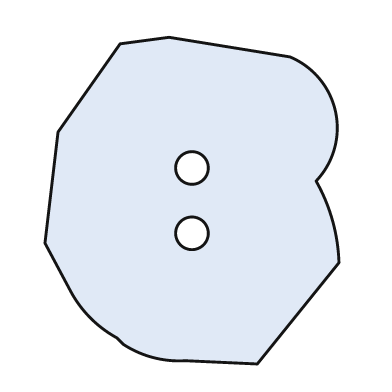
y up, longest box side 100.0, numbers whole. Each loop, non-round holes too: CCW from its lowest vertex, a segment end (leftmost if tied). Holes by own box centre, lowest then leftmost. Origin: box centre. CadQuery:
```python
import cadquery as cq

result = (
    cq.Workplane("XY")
    .moveTo(20.0, -50.0)
    .lineTo(45.0, -19.0)
    .threePointArc((43.0, -6.0), (38.0, 6.0))
    .threePointArc((44.0, 27.0), (30.0, 44.0))
    .lineTo(-7.0, 50.0)
    .lineTo(-22.0, 48.0)
    .lineTo(-41.0, 21.0)
    .lineTo(-45.0, -13.0)
    .lineTo(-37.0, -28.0)
    .threePointArc((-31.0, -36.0), (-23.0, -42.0))
    .lineTo(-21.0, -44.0)
    .threePointArc((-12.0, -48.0), (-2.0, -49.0))
    .close()
    .moveTo(0.0, -10.0)
    .circle(5.0)
    .moveTo(0.0, 10.0)
    .circle(5.0)
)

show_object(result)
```